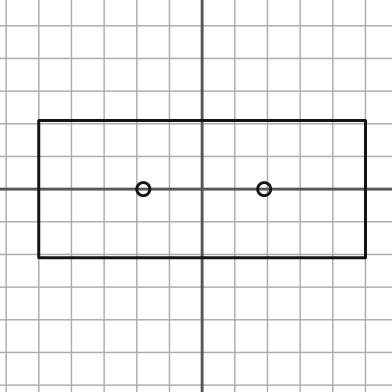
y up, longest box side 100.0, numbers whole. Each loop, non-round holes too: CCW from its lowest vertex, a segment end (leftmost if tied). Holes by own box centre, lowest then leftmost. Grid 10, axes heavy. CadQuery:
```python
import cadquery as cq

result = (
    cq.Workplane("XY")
    .moveTo(-50.0, -21.0)
    .lineTo(50.0, -21.0)
    .lineTo(50.0, 21.0)
    .lineTo(-50.0, 21.0)
    .close()
    .moveTo(-18.0, 0.0)
    .circle(2.0)
    .moveTo(19.0, 0.0)
    .circle(2.0)
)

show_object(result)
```